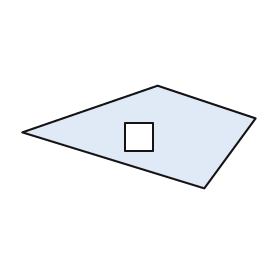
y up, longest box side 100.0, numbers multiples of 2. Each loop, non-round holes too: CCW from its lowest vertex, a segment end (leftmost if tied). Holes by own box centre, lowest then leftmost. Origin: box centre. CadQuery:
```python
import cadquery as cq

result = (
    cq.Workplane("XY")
    .moveTo(28.0, -22.0)
    .lineTo(50.0, 8.0)
    .lineTo(8.0, 22.0)
    .lineTo(-50.0, 2.0)
    .close()
    .moveTo(-6.0, -6.0)
    .lineTo(6.0, -6.0)
    .lineTo(6.0, 6.0)
    .lineTo(-6.0, 6.0)
    .close()
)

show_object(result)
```